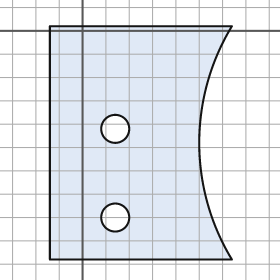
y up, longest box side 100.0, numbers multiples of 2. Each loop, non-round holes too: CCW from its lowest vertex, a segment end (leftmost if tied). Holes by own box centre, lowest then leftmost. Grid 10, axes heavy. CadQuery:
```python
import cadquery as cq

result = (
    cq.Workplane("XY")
    .moveTo(-14.0, -98.0)
    .lineTo(64.0, -98.0)
    .threePointArc((50.0, -48.0), (64.0, 2.0))
    .lineTo(-14.0, 2.0)
    .close()
    .moveTo(14.0, -80.0)
    .circle(6.0)
    .moveTo(14.0, -42.0)
    .circle(6.0)
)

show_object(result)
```